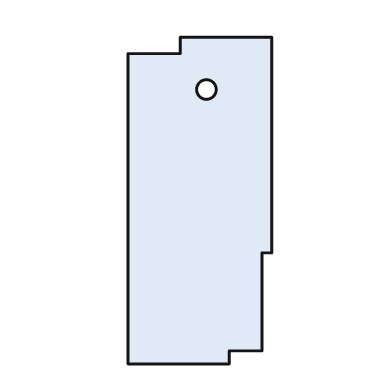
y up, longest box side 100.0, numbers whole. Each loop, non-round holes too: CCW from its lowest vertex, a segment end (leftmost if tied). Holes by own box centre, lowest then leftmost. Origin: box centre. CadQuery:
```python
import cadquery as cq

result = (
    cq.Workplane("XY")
    .moveTo(-22.0, -50.0)
    .lineTo(9.0, -50.0)
    .lineTo(9.0, -46.0)
    .lineTo(19.0, -46.0)
    .lineTo(19.0, -16.0)
    .lineTo(22.0, -16.0)
    .lineTo(22.0, 50.0)
    .lineTo(-6.0, 50.0)
    .lineTo(-6.0, 45.0)
    .lineTo(-22.0, 45.0)
    .close()
    .moveTo(2.0, 34.0)
    .circle(3.0)
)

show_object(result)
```